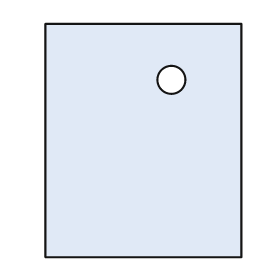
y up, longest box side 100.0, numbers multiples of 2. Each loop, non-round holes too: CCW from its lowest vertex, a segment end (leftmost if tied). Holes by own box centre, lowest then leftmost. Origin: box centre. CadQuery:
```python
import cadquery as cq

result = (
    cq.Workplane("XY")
    .moveTo(-42.0, -50.0)
    .lineTo(42.0, -50.0)
    .lineTo(42.0, 50.0)
    .lineTo(-42.0, 50.0)
    .close()
    .moveTo(12.0, 26.0)
    .circle(6.0)
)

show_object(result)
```